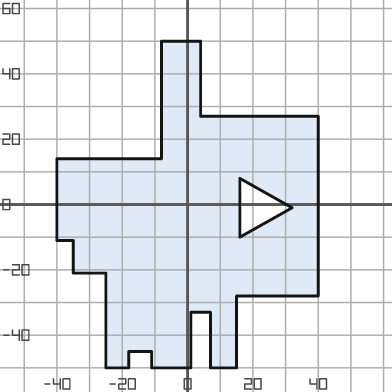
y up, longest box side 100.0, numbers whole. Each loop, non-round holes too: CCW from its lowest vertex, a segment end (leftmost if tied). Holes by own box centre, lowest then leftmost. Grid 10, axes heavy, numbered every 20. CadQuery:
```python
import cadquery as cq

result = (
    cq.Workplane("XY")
    .moveTo(-25.0, -50.0)
    .lineTo(-18.0, -50.0)
    .lineTo(-18.0, -45.0)
    .lineTo(-11.0, -45.0)
    .lineTo(-11.0, -50.0)
    .lineTo(1.0, -50.0)
    .lineTo(1.0, -33.0)
    .lineTo(7.0, -33.0)
    .lineTo(7.0, -50.0)
    .lineTo(15.0, -50.0)
    .lineTo(15.0, -28.0)
    .lineTo(40.0, -28.0)
    .lineTo(40.0, 27.0)
    .lineTo(4.0, 27.0)
    .lineTo(4.0, 50.0)
    .lineTo(-8.0, 50.0)
    .lineTo(-8.0, 14.0)
    .lineTo(-40.0, 14.0)
    .lineTo(-40.0, -11.0)
    .lineTo(-35.0, -11.0)
    .lineTo(-35.0, -21.0)
    .lineTo(-25.0, -21.0)
    .close()
    .moveTo(16.0, -10.0)
    .lineTo(32.0, -1.0)
    .lineTo(16.0, 8.0)
    .close()
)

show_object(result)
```